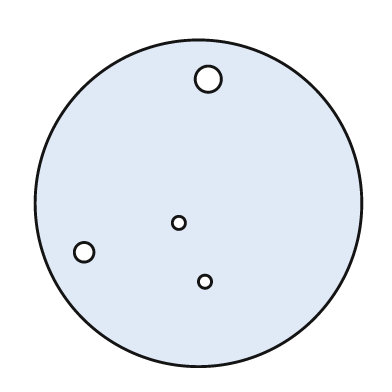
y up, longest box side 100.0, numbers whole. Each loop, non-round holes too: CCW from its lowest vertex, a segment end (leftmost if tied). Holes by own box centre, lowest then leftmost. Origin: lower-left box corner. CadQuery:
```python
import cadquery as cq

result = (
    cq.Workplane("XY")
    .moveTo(50.0, 50.0)
    .circle(50.0)
    .moveTo(52.0, 26.0)
    .circle(2.0)
    .moveTo(15.0, 35.0)
    .circle(3.0)
    .moveTo(44.0, 44.0)
    .circle(2.0)
    .moveTo(53.0, 88.0)
    .circle(4.0)
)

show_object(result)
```